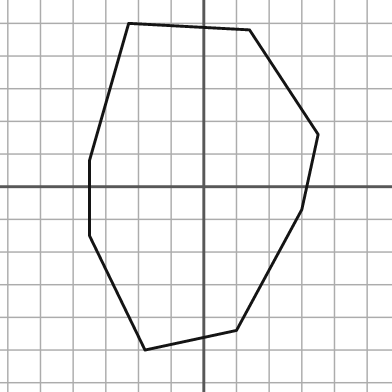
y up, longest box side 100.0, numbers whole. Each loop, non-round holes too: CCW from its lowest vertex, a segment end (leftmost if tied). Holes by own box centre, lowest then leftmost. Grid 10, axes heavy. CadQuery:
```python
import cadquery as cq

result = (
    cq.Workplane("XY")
    .moveTo(-18.0, -50.0)
    .lineTo(10.0, -44.0)
    .lineTo(30.0, -7.0)
    .lineTo(35.0, 16.0)
    .lineTo(14.0, 48.0)
    .lineTo(-23.0, 50.0)
    .lineTo(-35.0, 8.0)
    .lineTo(-35.0, -15.0)
    .close()
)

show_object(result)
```